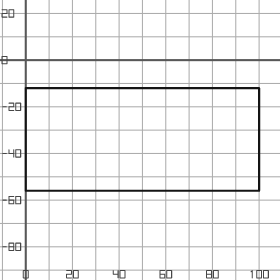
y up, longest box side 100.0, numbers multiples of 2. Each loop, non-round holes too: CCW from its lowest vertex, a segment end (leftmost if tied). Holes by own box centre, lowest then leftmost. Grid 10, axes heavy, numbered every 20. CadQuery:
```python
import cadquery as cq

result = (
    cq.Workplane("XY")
    .moveTo(0.0, -56.0)
    .lineTo(100.0, -56.0)
    .lineTo(100.0, -12.0)
    .lineTo(0.0, -12.0)
    .close()
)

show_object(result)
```